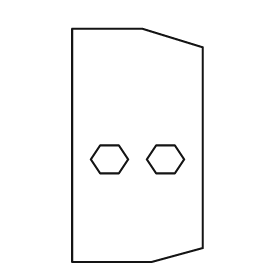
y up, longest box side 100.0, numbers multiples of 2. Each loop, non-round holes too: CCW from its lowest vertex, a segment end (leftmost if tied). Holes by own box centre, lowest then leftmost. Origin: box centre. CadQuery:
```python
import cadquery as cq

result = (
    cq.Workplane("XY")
    .moveTo(-28.0, -50.0)
    .lineTo(6.0, -50.0)
    .lineTo(28.0, -44.0)
    .lineTo(28.0, 42.0)
    .lineTo(2.0, 50.0)
    .lineTo(-28.0, 50.0)
    .close()
    .moveTo(-16.0, -12.0)
    .lineTo(-8.0, -12.0)
    .lineTo(-4.0, -6.0)
    .lineTo(-8.0, 0.0)
    .lineTo(-16.0, 0.0)
    .lineTo(-20.0, -6.0)
    .close()
    .moveTo(8.0, -12.0)
    .lineTo(16.0, -12.0)
    .lineTo(20.0, -6.0)
    .lineTo(16.0, 0.0)
    .lineTo(8.0, 0.0)
    .lineTo(4.0, -6.0)
    .close()
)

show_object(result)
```